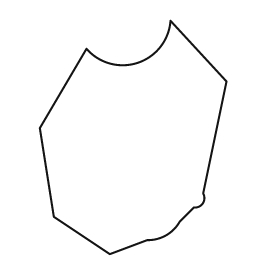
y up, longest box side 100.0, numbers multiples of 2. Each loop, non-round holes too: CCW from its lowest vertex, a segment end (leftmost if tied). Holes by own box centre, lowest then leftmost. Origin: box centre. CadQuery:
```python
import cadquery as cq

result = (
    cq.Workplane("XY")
    .moveTo(-10.0, -50.0)
    .lineTo(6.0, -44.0)
    .threePointArc((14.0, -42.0), (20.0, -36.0))
    .lineTo(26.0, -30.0)
    .threePointArc((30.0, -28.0), (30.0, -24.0))
    .lineTo(40.0, 24.0)
    .lineTo(16.0, 50.0)
    .threePointArc((2.0, 32.0), (-20.0, 38.0))
    .lineTo(-40.0, 4.0)
    .lineTo(-34.0, -34.0)
    .close()
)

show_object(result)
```